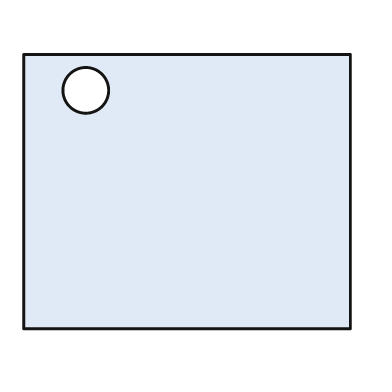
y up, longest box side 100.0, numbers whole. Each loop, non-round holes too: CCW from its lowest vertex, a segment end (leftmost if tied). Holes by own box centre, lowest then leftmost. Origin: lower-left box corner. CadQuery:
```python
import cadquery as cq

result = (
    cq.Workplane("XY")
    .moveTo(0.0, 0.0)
    .lineTo(100.0, 0.0)
    .lineTo(100.0, 84.0)
    .lineTo(0.0, 84.0)
    .close()
    .moveTo(19.0, 73.0)
    .circle(7.0)
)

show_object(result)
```